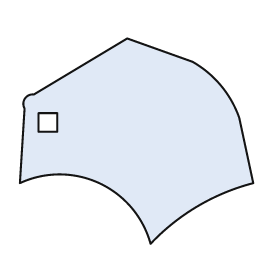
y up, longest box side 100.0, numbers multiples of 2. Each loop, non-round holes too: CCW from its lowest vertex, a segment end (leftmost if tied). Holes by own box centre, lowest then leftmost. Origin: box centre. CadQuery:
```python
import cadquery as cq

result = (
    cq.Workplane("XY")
    .moveTo(6.0, -44.0)
    .threePointArc((26.0, -28.0), (50.0, -18.0))
    .lineTo(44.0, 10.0)
    .threePointArc((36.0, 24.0), (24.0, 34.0))
    .lineTo(-4.0, 44.0)
    .lineTo(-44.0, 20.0)
    .threePointArc((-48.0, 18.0), (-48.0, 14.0))
    .lineTo(-50.0, -18.0)
    .threePointArc((-16.0, -18.0), (6.0, -44.0))
    .close()
    .moveTo(-42.0, 4.0)
    .lineTo(-34.0, 4.0)
    .lineTo(-34.0, 12.0)
    .lineTo(-42.0, 12.0)
    .close()
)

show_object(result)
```